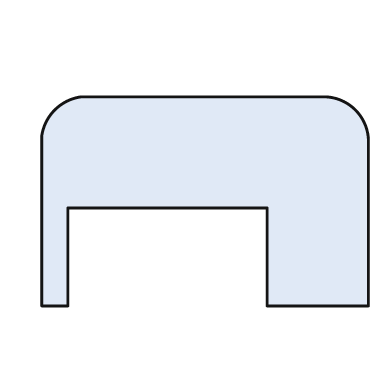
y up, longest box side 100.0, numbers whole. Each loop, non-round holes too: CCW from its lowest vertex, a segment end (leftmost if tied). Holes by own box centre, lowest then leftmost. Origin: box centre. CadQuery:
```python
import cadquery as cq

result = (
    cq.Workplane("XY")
    .moveTo(-50.0, -32.0)
    .lineTo(-42.0, -32.0)
    .lineTo(-42.0, -2.0)
    .lineTo(19.0, -2.0)
    .lineTo(19.0, -32.0)
    .lineTo(50.0, -32.0)
    .lineTo(50.0, 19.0)
    .threePointArc((46.0, 28.0), (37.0, 32.0))
    .lineTo(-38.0, 32.0)
    .threePointArc((-46.0, 28.0), (-50.0, 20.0))
    .close()
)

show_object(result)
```